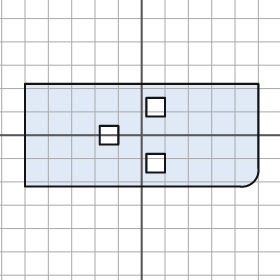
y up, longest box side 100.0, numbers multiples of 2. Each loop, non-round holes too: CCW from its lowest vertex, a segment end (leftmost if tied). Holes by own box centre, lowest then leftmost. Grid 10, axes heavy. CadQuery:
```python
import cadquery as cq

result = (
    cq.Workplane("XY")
    .moveTo(-50.0, -22.0)
    .lineTo(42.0, -22.0)
    .threePointArc((48.0, -20.0), (50.0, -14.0))
    .lineTo(50.0, 22.0)
    .lineTo(-50.0, 22.0)
    .close()
    .moveTo(2.0, -16.0)
    .lineTo(10.0, -16.0)
    .lineTo(10.0, -8.0)
    .lineTo(2.0, -8.0)
    .close()
    .moveTo(-18.0, -4.0)
    .lineTo(-10.0, -4.0)
    .lineTo(-10.0, 4.0)
    .lineTo(-18.0, 4.0)
    .close()
    .moveTo(2.0, 8.0)
    .lineTo(10.0, 8.0)
    .lineTo(10.0, 16.0)
    .lineTo(2.0, 16.0)
    .close()
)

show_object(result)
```